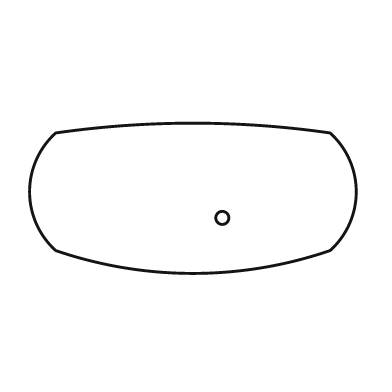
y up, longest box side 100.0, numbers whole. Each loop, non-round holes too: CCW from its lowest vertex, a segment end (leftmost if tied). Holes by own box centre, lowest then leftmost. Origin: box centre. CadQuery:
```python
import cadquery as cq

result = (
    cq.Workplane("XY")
    .moveTo(-42.0, -16.0)
    .threePointArc((0.0, -23.0), (42.0, -16.0))
    .threePointArc((50.0, 2.0), (42.0, 20.0))
    .threePointArc((0.0, 23.0), (-42.0, 20.0))
    .threePointArc((-50.0, 2.0), (-42.0, -16.0))
    .close()
    .moveTo(9.0, -6.0)
    .circle(2.0)
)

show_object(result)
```